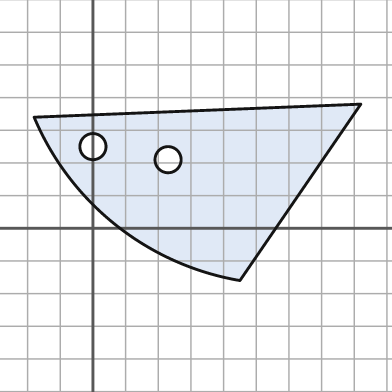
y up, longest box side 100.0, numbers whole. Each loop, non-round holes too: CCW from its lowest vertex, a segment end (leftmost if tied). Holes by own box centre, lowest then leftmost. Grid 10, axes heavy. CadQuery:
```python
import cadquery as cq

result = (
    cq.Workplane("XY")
    .moveTo(45.0, -16.0)
    .lineTo(82.0, 38.0)
    .lineTo(-18.0, 34.0)
    .threePointArc((7.0, 1.0), (45.0, -16.0))
    .close()
    .moveTo(23.0, 21.0)
    .circle(4.0)
    .moveTo(0.0, 25.0)
    .circle(4.0)
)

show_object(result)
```